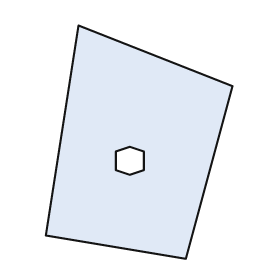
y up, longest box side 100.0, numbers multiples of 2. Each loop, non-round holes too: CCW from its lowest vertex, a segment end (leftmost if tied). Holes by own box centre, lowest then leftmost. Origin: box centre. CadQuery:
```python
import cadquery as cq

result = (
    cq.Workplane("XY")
    .moveTo(20.0, -50.0)
    .lineTo(40.0, 24.0)
    .lineTo(-26.0, 50.0)
    .lineTo(-40.0, -40.0)
    .close()
    .moveTo(-4.0, -14.0)
    .lineTo(2.0, -12.0)
    .lineTo(2.0, -4.0)
    .lineTo(-4.0, -2.0)
    .lineTo(-10.0, -4.0)
    .lineTo(-10.0, -12.0)
    .close()
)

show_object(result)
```